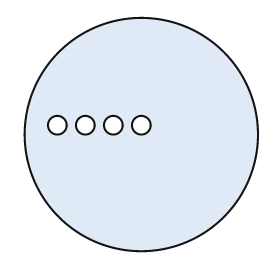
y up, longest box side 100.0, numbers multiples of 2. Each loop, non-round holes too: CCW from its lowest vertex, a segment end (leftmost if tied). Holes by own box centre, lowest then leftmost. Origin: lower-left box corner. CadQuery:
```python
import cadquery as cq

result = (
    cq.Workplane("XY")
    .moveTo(50.0, 50.0)
    .circle(50.0)
    .moveTo(14.0, 54.0)
    .circle(4.0)
    .moveTo(26.0, 54.0)
    .circle(4.0)
    .moveTo(38.0, 54.0)
    .circle(4.0)
    .moveTo(50.0, 54.0)
    .circle(4.0)
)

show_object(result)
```